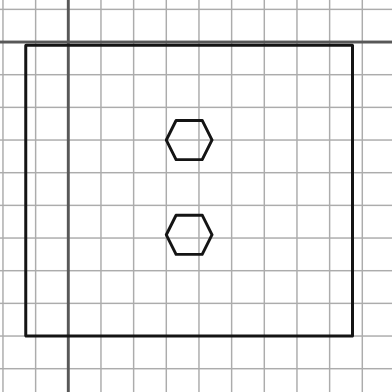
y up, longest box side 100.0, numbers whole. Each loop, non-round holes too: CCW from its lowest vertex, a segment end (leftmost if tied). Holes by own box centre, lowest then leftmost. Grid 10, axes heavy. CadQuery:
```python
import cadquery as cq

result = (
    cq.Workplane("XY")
    .moveTo(-13.0, -90.0)
    .lineTo(87.0, -90.0)
    .lineTo(87.0, -1.0)
    .lineTo(-13.0, -1.0)
    .close()
    .moveTo(33.0, -65.0)
    .lineTo(41.0, -65.0)
    .lineTo(44.0, -59.0)
    .lineTo(41.0, -53.0)
    .lineTo(33.0, -53.0)
    .lineTo(30.0, -59.0)
    .close()
    .moveTo(33.0, -36.0)
    .lineTo(41.0, -36.0)
    .lineTo(44.0, -30.0)
    .lineTo(41.0, -24.0)
    .lineTo(33.0, -24.0)
    .lineTo(30.0, -30.0)
    .close()
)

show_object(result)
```